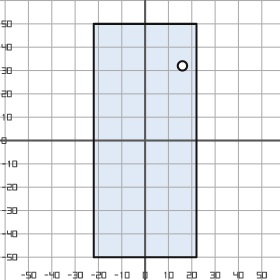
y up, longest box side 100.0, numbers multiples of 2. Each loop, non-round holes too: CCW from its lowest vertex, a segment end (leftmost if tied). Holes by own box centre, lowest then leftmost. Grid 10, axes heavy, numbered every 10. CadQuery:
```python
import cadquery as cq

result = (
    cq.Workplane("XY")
    .moveTo(-22.0, -50.0)
    .lineTo(22.0, -50.0)
    .lineTo(22.0, 50.0)
    .lineTo(-22.0, 50.0)
    .close()
    .moveTo(16.0, 32.0)
    .circle(2.0)
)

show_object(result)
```